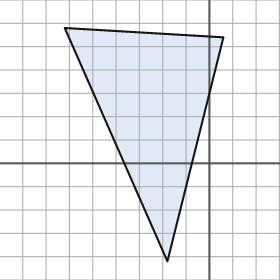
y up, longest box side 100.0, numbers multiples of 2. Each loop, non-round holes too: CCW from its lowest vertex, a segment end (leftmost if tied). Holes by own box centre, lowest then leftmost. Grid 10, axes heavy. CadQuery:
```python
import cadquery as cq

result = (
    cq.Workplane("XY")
    .moveTo(-18.0, -42.0)
    .lineTo(6.0, 54.0)
    .lineTo(-62.0, 58.0)
    .close()
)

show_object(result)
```